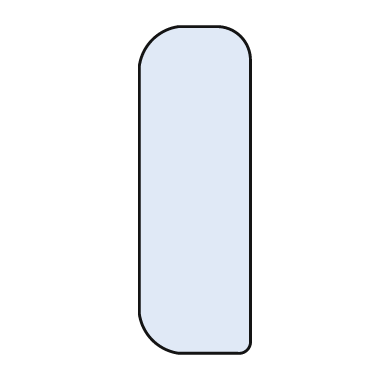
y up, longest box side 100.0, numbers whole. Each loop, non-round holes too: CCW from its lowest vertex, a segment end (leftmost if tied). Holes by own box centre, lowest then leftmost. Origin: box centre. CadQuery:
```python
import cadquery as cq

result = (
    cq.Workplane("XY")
    .moveTo(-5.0, -50.0)
    .lineTo(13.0, -50.0)
    .threePointArc((16.0, -49.0), (17.0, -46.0))
    .lineTo(17.0, 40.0)
    .threePointArc((14.0, 47.0), (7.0, 50.0))
    .lineTo(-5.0, 50.0)
    .threePointArc((-13.0, 46.0), (-17.0, 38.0))
    .lineTo(-17.0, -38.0)
    .threePointArc((-13.0, -46.0), (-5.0, -50.0))
    .close()
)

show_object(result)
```